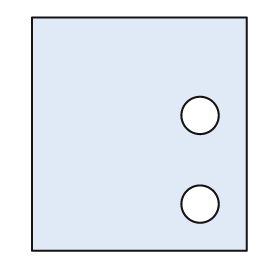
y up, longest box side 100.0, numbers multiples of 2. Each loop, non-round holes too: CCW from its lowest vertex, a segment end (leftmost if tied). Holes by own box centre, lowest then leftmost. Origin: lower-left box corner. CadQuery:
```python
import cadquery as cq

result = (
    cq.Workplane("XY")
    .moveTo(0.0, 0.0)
    .lineTo(92.0, 0.0)
    .lineTo(92.0, 100.0)
    .lineTo(0.0, 100.0)
    .close()
    .moveTo(72.0, 20.0)
    .circle(8.0)
    .moveTo(72.0, 58.0)
    .circle(8.0)
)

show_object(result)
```